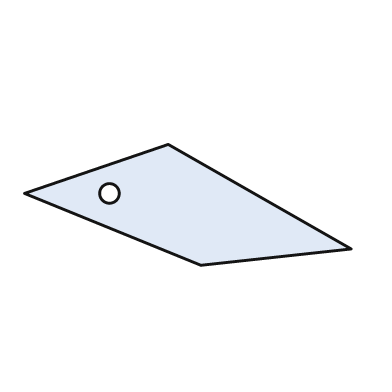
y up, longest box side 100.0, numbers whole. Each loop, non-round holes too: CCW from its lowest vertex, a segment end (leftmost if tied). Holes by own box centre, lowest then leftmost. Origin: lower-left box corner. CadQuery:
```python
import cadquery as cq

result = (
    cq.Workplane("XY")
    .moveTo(54.0, 0.0)
    .lineTo(100.0, 5.0)
    .lineTo(44.0, 37.0)
    .lineTo(0.0, 22.0)
    .close()
    .moveTo(26.0, 22.0)
    .circle(3.0)
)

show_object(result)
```